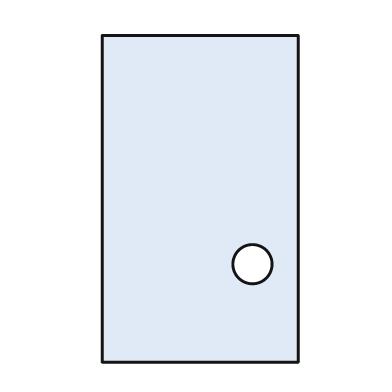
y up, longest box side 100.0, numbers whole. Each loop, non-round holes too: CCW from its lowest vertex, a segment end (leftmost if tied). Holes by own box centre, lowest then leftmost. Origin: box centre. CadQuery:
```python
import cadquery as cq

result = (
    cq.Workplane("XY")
    .moveTo(-30.0, -50.0)
    .lineTo(30.0, -50.0)
    .lineTo(30.0, 50.0)
    .lineTo(-30.0, 50.0)
    .close()
    .moveTo(16.0, -20.0)
    .circle(6.0)
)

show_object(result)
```